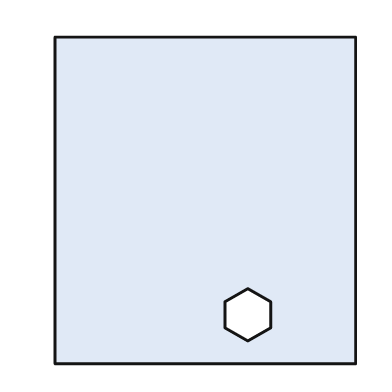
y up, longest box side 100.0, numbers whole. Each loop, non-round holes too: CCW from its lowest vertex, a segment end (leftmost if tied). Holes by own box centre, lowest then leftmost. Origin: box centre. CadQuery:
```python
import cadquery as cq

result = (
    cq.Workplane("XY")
    .moveTo(-46.0, -50.0)
    .lineTo(46.0, -50.0)
    .lineTo(46.0, 50.0)
    .lineTo(-46.0, 50.0)
    .close()
    .moveTo(13.0, -43.0)
    .lineTo(20.0, -39.0)
    .lineTo(20.0, -31.0)
    .lineTo(13.0, -27.0)
    .lineTo(6.0, -31.0)
    .lineTo(6.0, -39.0)
    .close()
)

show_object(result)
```